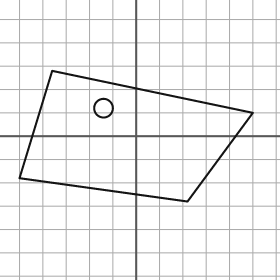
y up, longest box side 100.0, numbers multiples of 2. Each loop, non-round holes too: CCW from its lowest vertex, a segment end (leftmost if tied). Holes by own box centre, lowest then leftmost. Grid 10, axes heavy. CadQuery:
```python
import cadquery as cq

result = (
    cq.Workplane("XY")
    .moveTo(22.0, -28.0)
    .lineTo(50.0, 10.0)
    .lineTo(-36.0, 28.0)
    .lineTo(-50.0, -18.0)
    .close()
    .moveTo(-14.0, 12.0)
    .circle(4.0)
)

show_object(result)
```